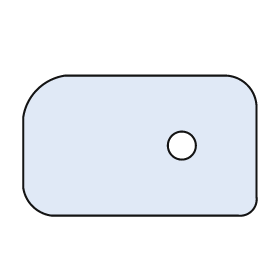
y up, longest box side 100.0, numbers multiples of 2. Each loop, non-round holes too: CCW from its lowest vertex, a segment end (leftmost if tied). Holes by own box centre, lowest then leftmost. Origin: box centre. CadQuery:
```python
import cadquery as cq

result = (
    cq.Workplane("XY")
    .moveTo(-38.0, -30.0)
    .lineTo(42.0, -30.0)
    .threePointArc((48.0, -28.0), (50.0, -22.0))
    .lineTo(50.0, 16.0)
    .threePointArc((46.0, 26.0), (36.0, 30.0))
    .lineTo(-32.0, 30.0)
    .threePointArc((-44.0, 24.0), (-50.0, 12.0))
    .lineTo(-50.0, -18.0)
    .threePointArc((-46.0, -26.0), (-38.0, -30.0))
    .close()
    .moveTo(18.0, 0.0)
    .circle(6.0)
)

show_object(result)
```